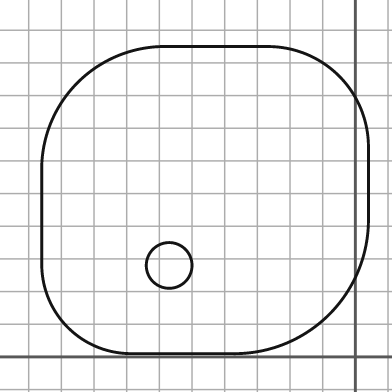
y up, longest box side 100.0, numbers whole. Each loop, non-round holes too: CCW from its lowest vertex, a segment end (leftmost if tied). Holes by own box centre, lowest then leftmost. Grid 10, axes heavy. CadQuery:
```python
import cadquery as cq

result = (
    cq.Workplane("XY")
    .moveTo(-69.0, 1.0)
    .lineTo(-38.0, 1.0)
    .threePointArc((-8.0, 13.0), (4.0, 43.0))
    .lineTo(4.0, 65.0)
    .threePointArc((-5.0, 86.0), (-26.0, 95.0))
    .lineTo(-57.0, 95.0)
    .threePointArc((-85.0, 84.0), (-96.0, 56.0))
    .lineTo(-96.0, 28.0)
    .threePointArc((-88.0, 9.0), (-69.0, 1.0))
    .close()
    .moveTo(-57.0, 28.0)
    .circle(7.0)
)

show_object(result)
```